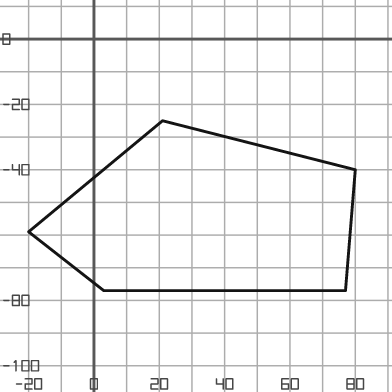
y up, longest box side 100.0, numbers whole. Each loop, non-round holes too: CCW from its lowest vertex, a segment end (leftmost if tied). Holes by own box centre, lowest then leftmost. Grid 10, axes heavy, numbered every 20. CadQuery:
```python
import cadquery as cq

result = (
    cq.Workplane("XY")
    .moveTo(3.0, -77.0)
    .lineTo(77.0, -77.0)
    .lineTo(80.0, -40.0)
    .lineTo(21.0, -25.0)
    .lineTo(-20.0, -59.0)
    .close()
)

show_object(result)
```